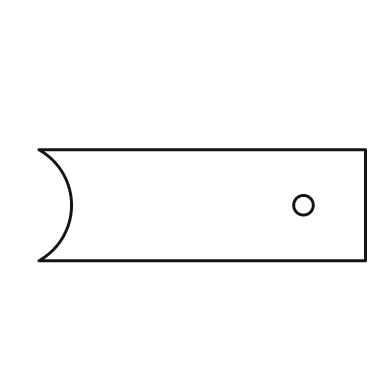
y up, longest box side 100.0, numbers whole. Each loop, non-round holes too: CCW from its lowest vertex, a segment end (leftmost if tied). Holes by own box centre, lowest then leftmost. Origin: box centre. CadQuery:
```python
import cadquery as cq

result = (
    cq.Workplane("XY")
    .moveTo(-50.0, -17.0)
    .lineTo(50.0, -17.0)
    .lineTo(50.0, 17.0)
    .lineTo(-50.0, 17.0)
    .threePointArc((-40.0, 0.0), (-50.0, -17.0))
    .close()
    .moveTo(31.0, 0.0)
    .circle(3.0)
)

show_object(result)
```